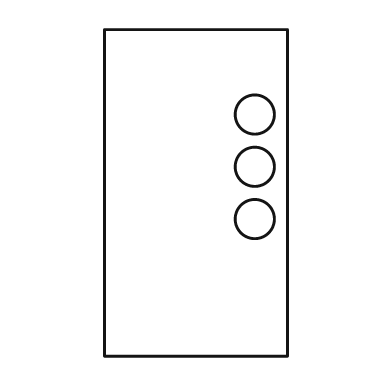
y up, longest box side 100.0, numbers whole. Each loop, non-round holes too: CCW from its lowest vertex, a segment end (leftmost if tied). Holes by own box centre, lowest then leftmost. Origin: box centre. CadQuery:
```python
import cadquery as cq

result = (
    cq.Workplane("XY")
    .moveTo(-28.0, -50.0)
    .lineTo(28.0, -50.0)
    .lineTo(28.0, 50.0)
    .lineTo(-28.0, 50.0)
    .close()
    .moveTo(18.0, -8.0)
    .circle(6.0)
    .moveTo(18.0, 8.0)
    .circle(6.0)
    .moveTo(18.0, 24.0)
    .circle(6.0)
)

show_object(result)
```